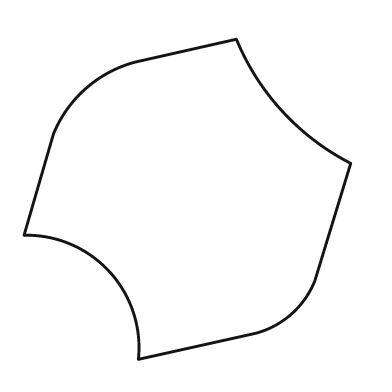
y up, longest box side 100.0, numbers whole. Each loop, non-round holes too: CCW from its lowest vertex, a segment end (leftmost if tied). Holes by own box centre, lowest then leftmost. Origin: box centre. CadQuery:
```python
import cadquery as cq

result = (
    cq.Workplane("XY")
    .moveTo(-15.0, -49.0)
    .lineTo(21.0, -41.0)
    .threePointArc((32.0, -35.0), (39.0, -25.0))
    .lineTo(50.0, 11.0)
    .threePointArc((29.0, 27.0), (15.0, 49.0))
    .lineTo(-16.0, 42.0)
    .threePointArc((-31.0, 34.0), (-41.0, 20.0))
    .lineTo(-50.0, -11.0)
    .threePointArc((-24.0, -22.0), (-15.0, -49.0))
    .close()
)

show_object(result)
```